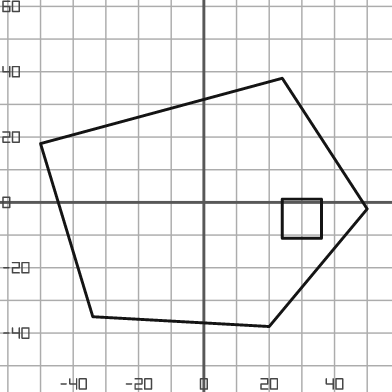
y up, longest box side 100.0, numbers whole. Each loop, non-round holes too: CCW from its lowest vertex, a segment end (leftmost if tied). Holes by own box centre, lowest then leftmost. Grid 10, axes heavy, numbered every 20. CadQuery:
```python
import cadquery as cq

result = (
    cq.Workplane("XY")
    .moveTo(20.0, -38.0)
    .lineTo(50.0, -2.0)
    .lineTo(24.0, 38.0)
    .lineTo(-50.0, 18.0)
    .lineTo(-34.0, -35.0)
    .close()
    .moveTo(24.0, -11.0)
    .lineTo(36.0, -11.0)
    .lineTo(36.0, 1.0)
    .lineTo(24.0, 1.0)
    .close()
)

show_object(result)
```